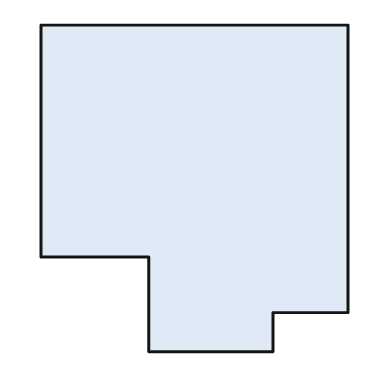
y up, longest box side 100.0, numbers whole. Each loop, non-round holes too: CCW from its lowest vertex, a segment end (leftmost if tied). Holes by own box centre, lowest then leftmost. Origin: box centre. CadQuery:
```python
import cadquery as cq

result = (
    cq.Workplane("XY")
    .moveTo(-14.0, -50.0)
    .lineTo(24.0, -50.0)
    .lineTo(24.0, -38.0)
    .lineTo(47.0, -38.0)
    .lineTo(47.0, 50.0)
    .lineTo(-47.0, 50.0)
    .lineTo(-47.0, -21.0)
    .lineTo(-14.0, -21.0)
    .close()
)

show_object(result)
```